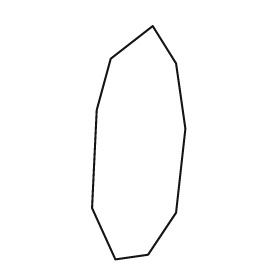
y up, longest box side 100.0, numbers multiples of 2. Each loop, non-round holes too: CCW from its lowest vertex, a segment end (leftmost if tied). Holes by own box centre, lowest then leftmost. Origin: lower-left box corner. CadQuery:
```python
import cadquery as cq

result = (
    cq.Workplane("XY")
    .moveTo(10.0, 0.0)
    .lineTo(24.0, 2.0)
    .lineTo(36.0, 20.0)
    .lineTo(40.0, 56.0)
    .lineTo(36.0, 84.0)
    .lineTo(26.0, 100.0)
    .lineTo(8.0, 86.0)
    .lineTo(2.0, 64.0)
    .lineTo(0.0, 22.0)
    .close()
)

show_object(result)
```